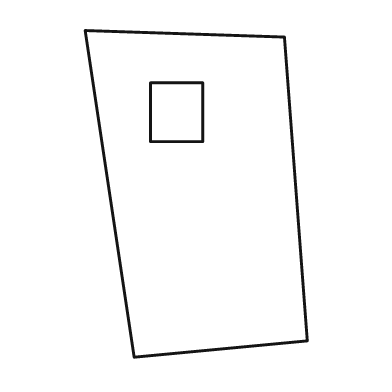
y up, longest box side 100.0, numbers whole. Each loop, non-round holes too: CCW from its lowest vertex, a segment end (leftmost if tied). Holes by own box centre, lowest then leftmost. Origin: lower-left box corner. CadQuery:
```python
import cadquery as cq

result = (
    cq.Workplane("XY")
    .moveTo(15.0, 0.0)
    .lineTo(68.0, 5.0)
    .lineTo(61.0, 98.0)
    .lineTo(0.0, 100.0)
    .close()
    .moveTo(20.0, 66.0)
    .lineTo(36.0, 66.0)
    .lineTo(36.0, 84.0)
    .lineTo(20.0, 84.0)
    .close()
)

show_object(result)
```